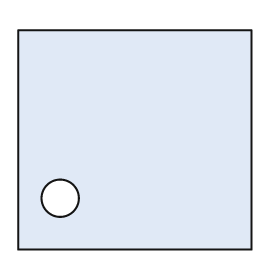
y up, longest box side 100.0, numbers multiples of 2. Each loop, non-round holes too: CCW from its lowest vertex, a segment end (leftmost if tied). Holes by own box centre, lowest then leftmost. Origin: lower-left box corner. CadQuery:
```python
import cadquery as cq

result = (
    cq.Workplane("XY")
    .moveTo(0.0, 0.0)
    .lineTo(100.0, 0.0)
    .lineTo(100.0, 94.0)
    .lineTo(0.0, 94.0)
    .close()
    .moveTo(18.0, 22.0)
    .circle(8.0)
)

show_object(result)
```